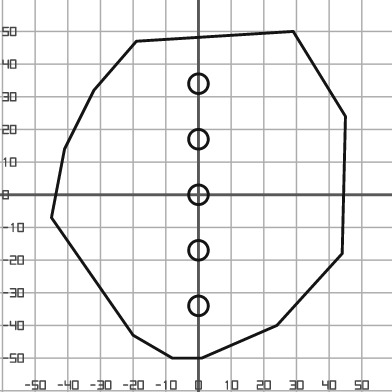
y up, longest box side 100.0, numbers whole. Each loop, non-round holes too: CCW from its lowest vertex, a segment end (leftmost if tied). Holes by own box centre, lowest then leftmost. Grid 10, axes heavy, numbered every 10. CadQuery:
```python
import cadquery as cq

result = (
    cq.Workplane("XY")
    .moveTo(-8.0, -50.0)
    .lineTo(1.0, -50.0)
    .lineTo(24.0, -40.0)
    .lineTo(44.0, -18.0)
    .lineTo(45.0, 24.0)
    .lineTo(29.0, 50.0)
    .lineTo(-19.0, 47.0)
    .lineTo(-32.0, 32.0)
    .lineTo(-41.0, 14.0)
    .lineTo(-45.0, -7.0)
    .lineTo(-20.0, -43.0)
    .close()
    .moveTo(0.0, -34.0)
    .circle(3.0)
    .moveTo(0.0, -17.0)
    .circle(3.0)
    .moveTo(0.0, 0.0)
    .circle(3.0)
    .moveTo(0.0, 17.0)
    .circle(3.0)
    .moveTo(0.0, 34.0)
    .circle(3.0)
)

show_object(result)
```